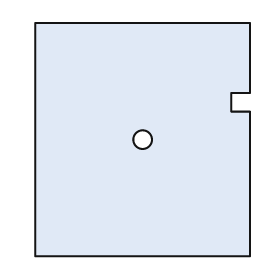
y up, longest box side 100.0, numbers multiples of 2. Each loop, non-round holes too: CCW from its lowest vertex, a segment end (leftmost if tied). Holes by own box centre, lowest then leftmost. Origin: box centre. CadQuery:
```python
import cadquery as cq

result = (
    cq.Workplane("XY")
    .moveTo(-46.0, -50.0)
    .lineTo(46.0, -50.0)
    .lineTo(46.0, 12.0)
    .lineTo(38.0, 12.0)
    .lineTo(38.0, 20.0)
    .lineTo(46.0, 20.0)
    .lineTo(46.0, 50.0)
    .lineTo(-46.0, 50.0)
    .close()
    .moveTo(0.0, 0.0)
    .circle(4.0)
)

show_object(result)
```